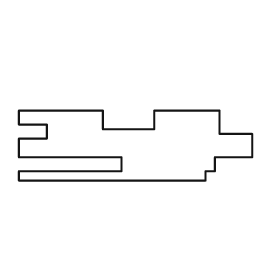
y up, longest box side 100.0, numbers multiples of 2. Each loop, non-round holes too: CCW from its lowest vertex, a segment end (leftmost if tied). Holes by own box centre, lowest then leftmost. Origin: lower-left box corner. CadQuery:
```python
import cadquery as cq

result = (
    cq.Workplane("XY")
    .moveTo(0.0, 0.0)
    .lineTo(80.0, 0.0)
    .lineTo(80.0, 4.0)
    .lineTo(84.0, 4.0)
    .lineTo(84.0, 10.0)
    .lineTo(100.0, 10.0)
    .lineTo(100.0, 20.0)
    .lineTo(86.0, 20.0)
    .lineTo(86.0, 30.0)
    .lineTo(58.0, 30.0)
    .lineTo(58.0, 22.0)
    .lineTo(36.0, 22.0)
    .lineTo(36.0, 30.0)
    .lineTo(0.0, 30.0)
    .lineTo(0.0, 24.0)
    .lineTo(12.0, 24.0)
    .lineTo(12.0, 18.0)
    .lineTo(0.0, 18.0)
    .lineTo(0.0, 10.0)
    .lineTo(44.0, 10.0)
    .lineTo(44.0, 4.0)
    .lineTo(0.0, 4.0)
    .close()
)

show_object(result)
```